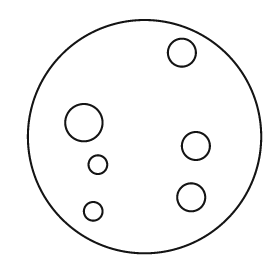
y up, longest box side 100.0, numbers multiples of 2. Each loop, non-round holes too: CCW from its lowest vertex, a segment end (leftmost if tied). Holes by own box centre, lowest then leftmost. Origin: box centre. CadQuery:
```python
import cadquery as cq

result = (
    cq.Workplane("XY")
    .moveTo(0.0, 0.0)
    .circle(50.0)
    .moveTo(-22.0, -32.0)
    .circle(4.0)
    .moveTo(20.0, -26.0)
    .circle(6.0)
    .moveTo(-20.0, -12.0)
    .circle(4.0)
    .moveTo(22.0, -4.0)
    .circle(6.0)
    .moveTo(-26.0, 6.0)
    .circle(8.0)
    .moveTo(16.0, 36.0)
    .circle(6.0)
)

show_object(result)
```